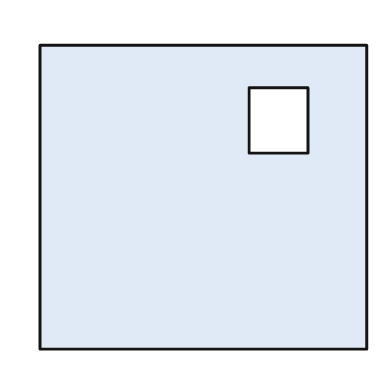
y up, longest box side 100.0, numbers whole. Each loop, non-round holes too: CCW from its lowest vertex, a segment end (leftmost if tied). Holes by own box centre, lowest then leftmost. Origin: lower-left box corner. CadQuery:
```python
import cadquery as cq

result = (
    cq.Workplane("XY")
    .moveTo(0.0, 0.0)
    .lineTo(100.0, 0.0)
    .lineTo(100.0, 93.0)
    .lineTo(0.0, 93.0)
    .close()
    .moveTo(64.0, 60.0)
    .lineTo(82.0, 60.0)
    .lineTo(82.0, 80.0)
    .lineTo(64.0, 80.0)
    .close()
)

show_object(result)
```